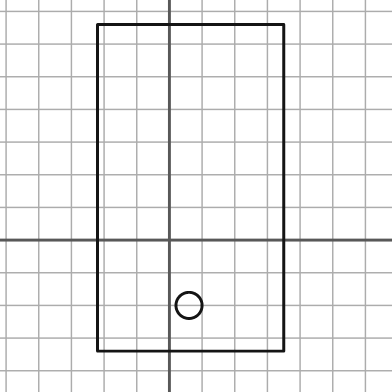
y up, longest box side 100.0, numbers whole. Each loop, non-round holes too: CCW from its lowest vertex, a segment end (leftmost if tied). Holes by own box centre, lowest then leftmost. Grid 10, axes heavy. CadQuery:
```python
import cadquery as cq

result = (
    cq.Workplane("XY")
    .moveTo(-22.0, -34.0)
    .lineTo(35.0, -34.0)
    .lineTo(35.0, 66.0)
    .lineTo(-22.0, 66.0)
    .close()
    .moveTo(6.0, -20.0)
    .circle(4.0)
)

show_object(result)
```